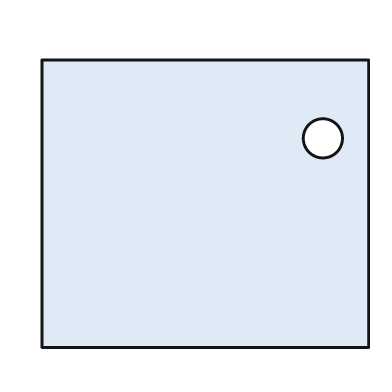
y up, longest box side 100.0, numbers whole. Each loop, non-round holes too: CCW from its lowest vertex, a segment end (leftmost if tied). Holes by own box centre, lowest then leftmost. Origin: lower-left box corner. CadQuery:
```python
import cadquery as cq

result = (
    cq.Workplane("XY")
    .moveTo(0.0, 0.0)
    .lineTo(100.0, 0.0)
    .lineTo(100.0, 88.0)
    .lineTo(0.0, 88.0)
    .close()
    .moveTo(86.0, 64.0)
    .circle(6.0)
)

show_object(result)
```